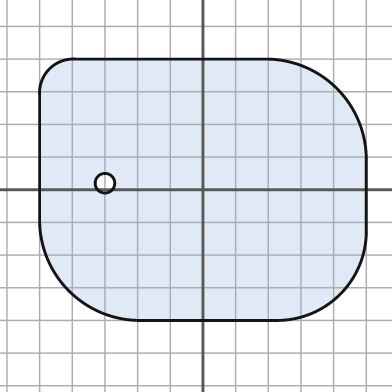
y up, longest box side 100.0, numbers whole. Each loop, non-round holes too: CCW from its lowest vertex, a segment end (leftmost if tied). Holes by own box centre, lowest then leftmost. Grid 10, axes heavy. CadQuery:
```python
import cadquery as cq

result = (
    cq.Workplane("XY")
    .moveTo(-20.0, -40.0)
    .lineTo(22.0, -40.0)
    .threePointArc((42.0, -32.0), (50.0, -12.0))
    .lineTo(50.0, 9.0)
    .threePointArc((41.0, 31.0), (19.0, 40.0))
    .lineTo(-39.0, 40.0)
    .threePointArc((-47.0, 37.0), (-50.0, 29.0))
    .lineTo(-50.0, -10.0)
    .threePointArc((-41.0, -31.0), (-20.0, -40.0))
    .close()
    .moveTo(-30.0, 2.0)
    .circle(3.0)
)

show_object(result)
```